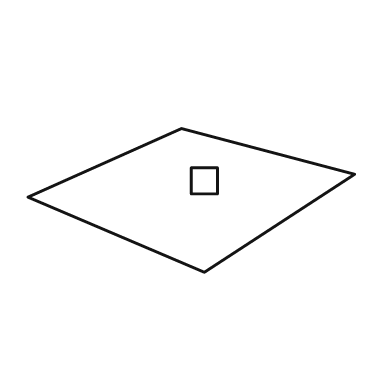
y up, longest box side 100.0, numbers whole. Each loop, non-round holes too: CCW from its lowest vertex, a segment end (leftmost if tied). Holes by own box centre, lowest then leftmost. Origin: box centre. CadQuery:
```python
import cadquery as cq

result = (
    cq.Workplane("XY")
    .moveTo(4.0, -22.0)
    .lineTo(50.0, 8.0)
    .lineTo(-3.0, 22.0)
    .lineTo(-50.0, 1.0)
    .close()
    .moveTo(0.0, 2.0)
    .lineTo(8.0, 2.0)
    .lineTo(8.0, 10.0)
    .lineTo(0.0, 10.0)
    .close()
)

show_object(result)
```